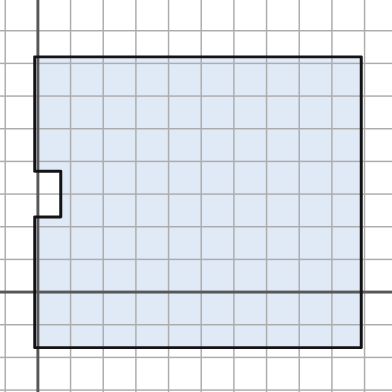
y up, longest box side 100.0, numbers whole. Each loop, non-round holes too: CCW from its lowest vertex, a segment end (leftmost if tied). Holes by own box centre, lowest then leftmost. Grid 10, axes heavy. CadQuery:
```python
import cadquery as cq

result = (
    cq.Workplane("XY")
    .moveTo(-1.0, -17.0)
    .lineTo(99.0, -17.0)
    .lineTo(99.0, 72.0)
    .lineTo(-1.0, 72.0)
    .lineTo(-1.0, 37.0)
    .lineTo(7.0, 37.0)
    .lineTo(7.0, 23.0)
    .lineTo(-1.0, 23.0)
    .close()
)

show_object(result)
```